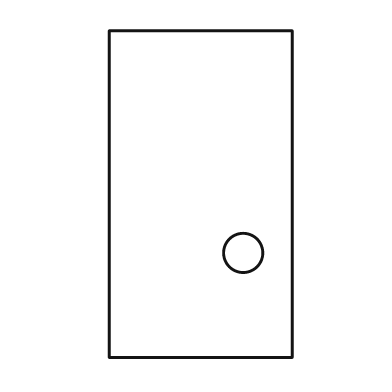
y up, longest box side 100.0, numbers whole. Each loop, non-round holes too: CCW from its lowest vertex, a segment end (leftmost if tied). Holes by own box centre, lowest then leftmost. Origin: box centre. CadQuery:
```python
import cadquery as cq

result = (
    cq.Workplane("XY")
    .moveTo(-28.0, -50.0)
    .lineTo(28.0, -50.0)
    .lineTo(28.0, 50.0)
    .lineTo(-28.0, 50.0)
    .close()
    .moveTo(13.0, -18.0)
    .circle(6.0)
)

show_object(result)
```